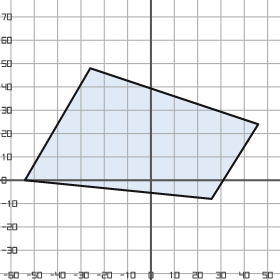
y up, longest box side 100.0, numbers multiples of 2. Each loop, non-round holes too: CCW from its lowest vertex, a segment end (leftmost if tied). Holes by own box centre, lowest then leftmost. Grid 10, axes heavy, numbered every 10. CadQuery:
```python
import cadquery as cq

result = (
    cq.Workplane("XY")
    .moveTo(26.0, -8.0)
    .lineTo(46.0, 24.0)
    .lineTo(-26.0, 48.0)
    .lineTo(-54.0, 0.0)
    .close()
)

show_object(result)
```